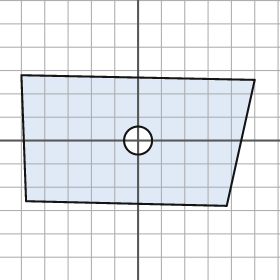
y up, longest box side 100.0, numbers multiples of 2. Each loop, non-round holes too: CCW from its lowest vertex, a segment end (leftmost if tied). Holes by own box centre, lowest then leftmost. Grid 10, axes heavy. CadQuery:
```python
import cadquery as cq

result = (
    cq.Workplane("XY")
    .moveTo(38.0, -28.0)
    .lineTo(50.0, 26.0)
    .lineTo(-50.0, 28.0)
    .lineTo(-48.0, -26.0)
    .close()
    .moveTo(0.0, 0.0)
    .circle(6.0)
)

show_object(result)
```